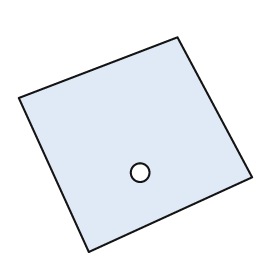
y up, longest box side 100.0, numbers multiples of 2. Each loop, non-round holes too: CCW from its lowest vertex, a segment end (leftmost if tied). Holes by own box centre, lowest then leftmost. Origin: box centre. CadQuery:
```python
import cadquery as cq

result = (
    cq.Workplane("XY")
    .moveTo(-20.0, -46.0)
    .lineTo(50.0, -14.0)
    .lineTo(18.0, 46.0)
    .lineTo(-50.0, 20.0)
    .close()
    .moveTo(2.0, -12.0)
    .circle(4.0)
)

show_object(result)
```